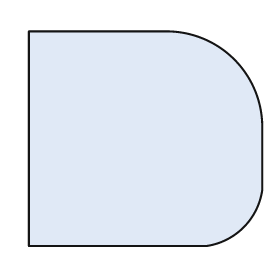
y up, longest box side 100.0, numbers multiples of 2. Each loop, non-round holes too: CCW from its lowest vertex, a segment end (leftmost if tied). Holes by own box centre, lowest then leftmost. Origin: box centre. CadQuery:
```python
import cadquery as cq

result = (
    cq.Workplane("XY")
    .moveTo(-50.0, -46.0)
    .lineTo(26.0, -46.0)
    .threePointArc((42.0, -38.0), (50.0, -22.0))
    .lineTo(50.0, 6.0)
    .threePointArc((38.0, 34.0), (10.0, 46.0))
    .lineTo(-50.0, 46.0)
    .close()
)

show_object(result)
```